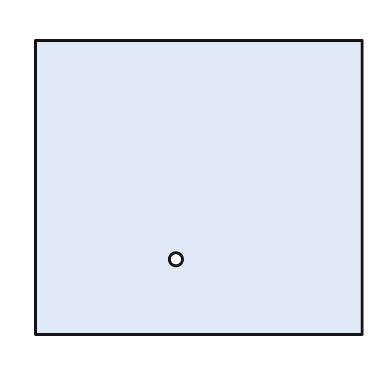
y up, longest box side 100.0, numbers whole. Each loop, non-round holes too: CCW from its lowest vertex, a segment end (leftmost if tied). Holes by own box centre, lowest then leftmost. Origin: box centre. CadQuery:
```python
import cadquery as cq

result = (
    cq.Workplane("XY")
    .moveTo(-50.0, -45.0)
    .lineTo(50.0, -45.0)
    .lineTo(50.0, 45.0)
    .lineTo(-50.0, 45.0)
    .close()
    .moveTo(-7.0, -22.0)
    .circle(2.0)
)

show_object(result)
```